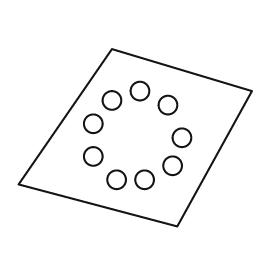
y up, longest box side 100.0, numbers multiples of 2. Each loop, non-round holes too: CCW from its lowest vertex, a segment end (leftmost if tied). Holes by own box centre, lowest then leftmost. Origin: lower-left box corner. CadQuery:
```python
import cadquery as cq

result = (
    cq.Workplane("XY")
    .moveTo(68.0, 0.0)
    .lineTo(100.0, 58.0)
    .lineTo(40.0, 76.0)
    .lineTo(0.0, 18.0)
    .close()
    .moveTo(42.0, 20.0)
    .circle(4.0)
    .moveTo(54.0, 20.0)
    .circle(4.0)
    .moveTo(66.0, 26.0)
    .circle(4.0)
    .moveTo(32.0, 30.0)
    .circle(4.0)
    .moveTo(70.0, 38.0)
    .circle(4.0)
    .moveTo(32.0, 44.0)
    .circle(4.0)
    .moveTo(64.0, 52.0)
    .circle(4.0)
    .moveTo(40.0, 54.0)
    .circle(4.0)
    .moveTo(52.0, 58.0)
    .circle(4.0)
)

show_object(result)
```